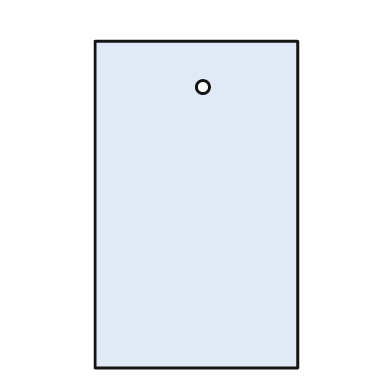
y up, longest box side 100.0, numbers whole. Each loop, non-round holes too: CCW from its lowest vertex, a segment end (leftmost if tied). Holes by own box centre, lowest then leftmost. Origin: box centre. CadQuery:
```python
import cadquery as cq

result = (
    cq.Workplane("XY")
    .moveTo(-31.0, -50.0)
    .lineTo(31.0, -50.0)
    .lineTo(31.0, 50.0)
    .lineTo(-31.0, 50.0)
    .close()
    .moveTo(2.0, 36.0)
    .circle(2.0)
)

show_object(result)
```